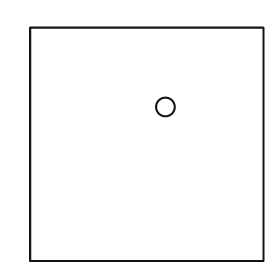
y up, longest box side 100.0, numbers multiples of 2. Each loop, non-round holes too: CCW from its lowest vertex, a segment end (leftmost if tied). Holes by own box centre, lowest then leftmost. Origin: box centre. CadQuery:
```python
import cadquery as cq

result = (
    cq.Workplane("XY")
    .moveTo(-50.0, -50.0)
    .lineTo(50.0, -50.0)
    .lineTo(50.0, 50.0)
    .lineTo(-50.0, 50.0)
    .close()
    .moveTo(8.0, 16.0)
    .circle(4.0)
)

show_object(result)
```